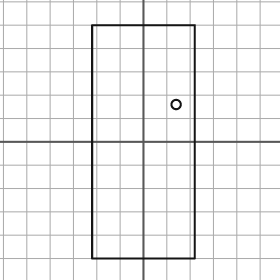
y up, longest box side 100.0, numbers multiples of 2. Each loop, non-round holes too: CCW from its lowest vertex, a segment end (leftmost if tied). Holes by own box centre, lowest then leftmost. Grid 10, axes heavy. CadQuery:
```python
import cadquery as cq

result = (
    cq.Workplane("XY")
    .moveTo(-22.0, -50.0)
    .lineTo(22.0, -50.0)
    .lineTo(22.0, 50.0)
    .lineTo(-22.0, 50.0)
    .close()
    .moveTo(14.0, 16.0)
    .circle(2.0)
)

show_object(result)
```